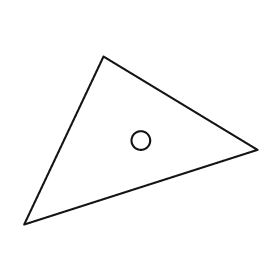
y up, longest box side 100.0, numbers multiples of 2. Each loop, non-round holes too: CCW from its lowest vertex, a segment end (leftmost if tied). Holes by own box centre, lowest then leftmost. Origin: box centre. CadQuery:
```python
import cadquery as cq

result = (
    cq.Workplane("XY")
    .moveTo(-50.0, -36.0)
    .lineTo(50.0, -4.0)
    .lineTo(-16.0, 36.0)
    .close()
    .moveTo(0.0, 0.0)
    .circle(4.0)
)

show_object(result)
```